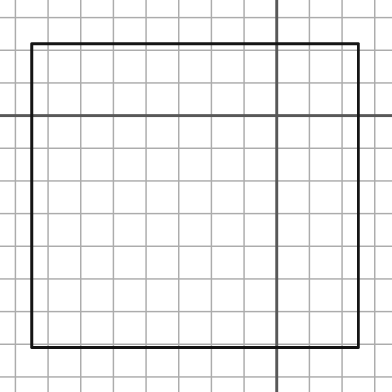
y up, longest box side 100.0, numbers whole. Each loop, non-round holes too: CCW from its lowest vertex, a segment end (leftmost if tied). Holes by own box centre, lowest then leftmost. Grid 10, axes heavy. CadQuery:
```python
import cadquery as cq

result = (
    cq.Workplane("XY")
    .moveTo(-75.0, -71.0)
    .lineTo(25.0, -71.0)
    .lineTo(25.0, 22.0)
    .lineTo(-75.0, 22.0)
    .close()
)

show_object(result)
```